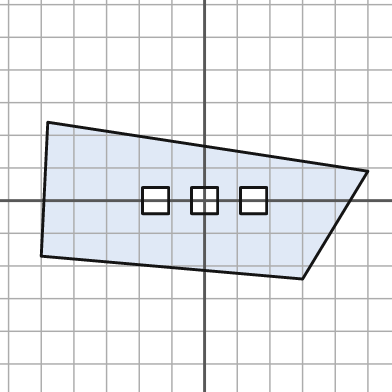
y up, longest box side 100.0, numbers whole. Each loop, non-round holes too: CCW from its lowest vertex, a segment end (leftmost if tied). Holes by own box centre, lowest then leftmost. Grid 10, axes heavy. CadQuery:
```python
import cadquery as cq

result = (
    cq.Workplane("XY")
    .moveTo(30.0, -24.0)
    .lineTo(50.0, 9.0)
    .lineTo(-48.0, 24.0)
    .lineTo(-50.0, -17.0)
    .close()
    .moveTo(-19.0, -4.0)
    .lineTo(-11.0, -4.0)
    .lineTo(-11.0, 4.0)
    .lineTo(-19.0, 4.0)
    .close()
    .moveTo(-4.0, -4.0)
    .lineTo(4.0, -4.0)
    .lineTo(4.0, 4.0)
    .lineTo(-4.0, 4.0)
    .close()
    .moveTo(11.0, -4.0)
    .lineTo(19.0, -4.0)
    .lineTo(19.0, 4.0)
    .lineTo(11.0, 4.0)
    .close()
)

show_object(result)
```